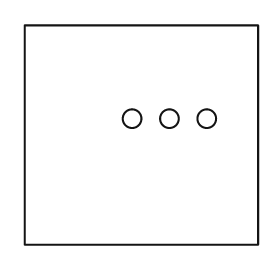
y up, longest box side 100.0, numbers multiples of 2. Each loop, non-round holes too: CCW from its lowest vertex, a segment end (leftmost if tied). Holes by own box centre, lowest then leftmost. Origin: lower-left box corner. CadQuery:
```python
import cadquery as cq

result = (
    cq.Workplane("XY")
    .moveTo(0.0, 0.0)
    .lineTo(100.0, 0.0)
    .lineTo(100.0, 94.0)
    .lineTo(0.0, 94.0)
    .close()
    .moveTo(46.0, 54.0)
    .circle(4.0)
    .moveTo(62.0, 54.0)
    .circle(4.0)
    .moveTo(78.0, 54.0)
    .circle(4.0)
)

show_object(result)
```